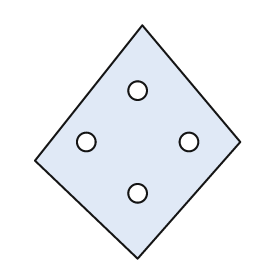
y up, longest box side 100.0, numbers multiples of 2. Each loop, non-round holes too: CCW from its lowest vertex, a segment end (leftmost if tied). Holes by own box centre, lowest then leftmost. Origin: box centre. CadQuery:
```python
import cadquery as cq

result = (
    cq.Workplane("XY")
    .moveTo(0.0, -50.0)
    .lineTo(44.0, 0.0)
    .lineTo(2.0, 50.0)
    .lineTo(-44.0, -8.0)
    .close()
    .moveTo(0.0, -22.0)
    .circle(4.0)
    .moveTo(-22.0, 0.0)
    .circle(4.0)
    .moveTo(22.0, 0.0)
    .circle(4.0)
    .moveTo(0.0, 22.0)
    .circle(4.0)
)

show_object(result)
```